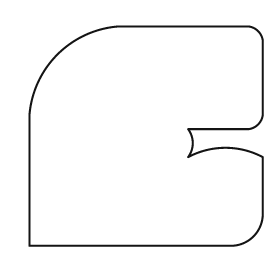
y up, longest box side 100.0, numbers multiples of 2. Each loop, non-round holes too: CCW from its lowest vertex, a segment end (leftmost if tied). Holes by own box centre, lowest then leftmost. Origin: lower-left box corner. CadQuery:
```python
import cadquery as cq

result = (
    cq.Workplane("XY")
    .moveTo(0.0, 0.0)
    .lineTo(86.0, 0.0)
    .threePointArc((96.0, 4.0), (100.0, 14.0))
    .lineTo(100.0, 38.0)
    .threePointArc((84.0, 42.0), (68.0, 38.0))
    .threePointArc((70.0, 44.0), (68.0, 50.0))
    .lineTo(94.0, 50.0)
    .threePointArc((98.0, 52.0), (100.0, 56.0))
    .lineTo(100.0, 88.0)
    .threePointArc((98.0, 92.0), (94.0, 94.0))
    .lineTo(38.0, 94.0)
    .threePointArc((12.0, 82.0), (0.0, 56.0))
    .close()
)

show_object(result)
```